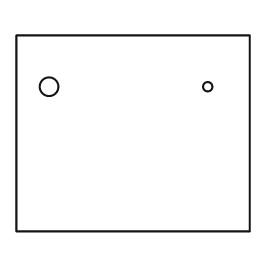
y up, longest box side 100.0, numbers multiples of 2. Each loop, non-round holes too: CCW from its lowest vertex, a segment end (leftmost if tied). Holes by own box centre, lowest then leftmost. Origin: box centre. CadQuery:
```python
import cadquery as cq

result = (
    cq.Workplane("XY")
    .moveTo(-50.0, -42.0)
    .lineTo(50.0, -42.0)
    .lineTo(50.0, 42.0)
    .lineTo(-50.0, 42.0)
    .close()
    .moveTo(-36.0, 20.0)
    .circle(4.0)
    .moveTo(32.0, 20.0)
    .circle(2.0)
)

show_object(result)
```